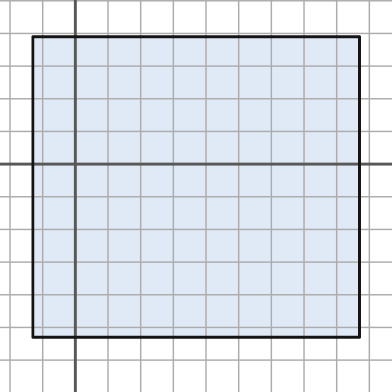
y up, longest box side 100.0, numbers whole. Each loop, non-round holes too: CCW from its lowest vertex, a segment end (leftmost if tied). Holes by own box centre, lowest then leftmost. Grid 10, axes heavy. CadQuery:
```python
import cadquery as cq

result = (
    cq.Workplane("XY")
    .moveTo(-13.0, -53.0)
    .lineTo(87.0, -53.0)
    .lineTo(87.0, 39.0)
    .lineTo(-13.0, 39.0)
    .close()
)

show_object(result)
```